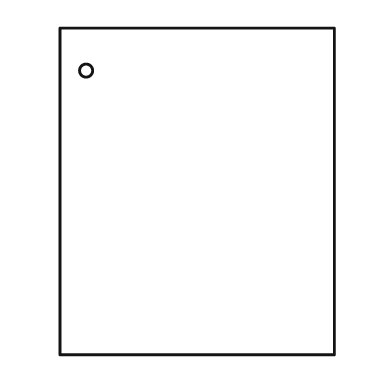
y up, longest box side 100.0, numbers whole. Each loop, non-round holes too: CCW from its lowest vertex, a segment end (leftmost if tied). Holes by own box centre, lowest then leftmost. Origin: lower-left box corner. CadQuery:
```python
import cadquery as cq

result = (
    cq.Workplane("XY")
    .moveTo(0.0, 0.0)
    .lineTo(84.0, 0.0)
    .lineTo(84.0, 100.0)
    .lineTo(0.0, 100.0)
    .close()
    .moveTo(8.0, 87.0)
    .circle(2.0)
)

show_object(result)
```